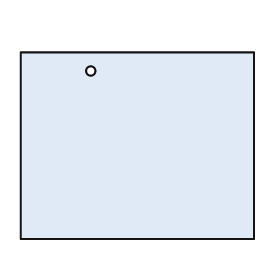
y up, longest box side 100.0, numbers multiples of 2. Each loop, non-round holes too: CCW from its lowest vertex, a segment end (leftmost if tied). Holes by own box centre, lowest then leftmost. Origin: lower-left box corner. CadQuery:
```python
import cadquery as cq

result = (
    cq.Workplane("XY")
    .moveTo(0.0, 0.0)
    .lineTo(100.0, 0.0)
    .lineTo(100.0, 80.0)
    .lineTo(0.0, 80.0)
    .close()
    .moveTo(30.0, 72.0)
    .circle(2.0)
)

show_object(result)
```